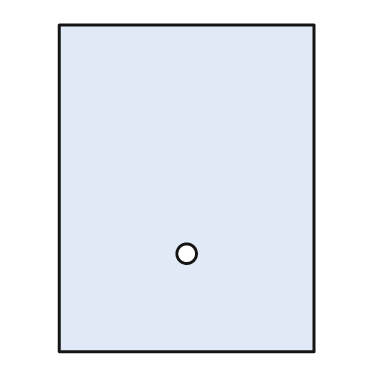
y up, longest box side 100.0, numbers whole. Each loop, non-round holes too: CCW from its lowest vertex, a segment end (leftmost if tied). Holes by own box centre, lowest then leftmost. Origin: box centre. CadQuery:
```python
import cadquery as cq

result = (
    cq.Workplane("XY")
    .moveTo(-39.0, -50.0)
    .lineTo(39.0, -50.0)
    .lineTo(39.0, 50.0)
    .lineTo(-39.0, 50.0)
    .close()
    .moveTo(0.0, -20.0)
    .circle(3.0)
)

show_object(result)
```